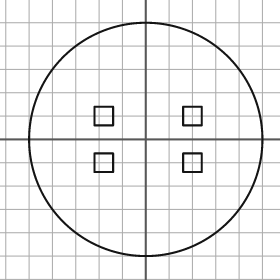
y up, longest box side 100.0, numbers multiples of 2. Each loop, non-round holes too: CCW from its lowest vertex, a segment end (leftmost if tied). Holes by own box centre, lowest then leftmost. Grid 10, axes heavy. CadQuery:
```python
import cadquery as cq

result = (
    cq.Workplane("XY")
    .moveTo(0.0, 0.0)
    .circle(50.0)
    .moveTo(-22.0, -14.0)
    .lineTo(-14.0, -14.0)
    .lineTo(-14.0, -6.0)
    .lineTo(-22.0, -6.0)
    .close()
    .moveTo(16.0, -14.0)
    .lineTo(24.0, -14.0)
    .lineTo(24.0, -6.0)
    .lineTo(16.0, -6.0)
    .close()
    .moveTo(-22.0, 6.0)
    .lineTo(-14.0, 6.0)
    .lineTo(-14.0, 14.0)
    .lineTo(-22.0, 14.0)
    .close()
    .moveTo(16.0, 6.0)
    .lineTo(24.0, 6.0)
    .lineTo(24.0, 14.0)
    .lineTo(16.0, 14.0)
    .close()
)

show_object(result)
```